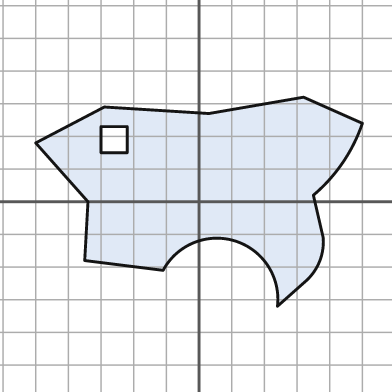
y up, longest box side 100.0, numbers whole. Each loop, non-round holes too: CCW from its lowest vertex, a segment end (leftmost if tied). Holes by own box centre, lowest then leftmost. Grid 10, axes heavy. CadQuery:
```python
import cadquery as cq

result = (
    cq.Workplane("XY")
    .moveTo(24.0, -32.0)
    .lineTo(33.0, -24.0)
    .threePointArc((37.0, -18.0), (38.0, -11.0))
    .lineTo(35.0, 2.0)
    .threePointArc((44.0, 12.0), (50.0, 24.0))
    .lineTo(32.0, 32.0)
    .lineTo(3.0, 27.0)
    .lineTo(-29.0, 29.0)
    .lineTo(-50.0, 18.0)
    .lineTo(-34.0, 0.0)
    .lineTo(-35.0, -18.0)
    .lineTo(-11.0, -21.0)
    .threePointArc((11.0, -12.0), (24.0, -32.0))
    .close()
    .moveTo(-30.0, 15.0)
    .lineTo(-22.0, 15.0)
    .lineTo(-22.0, 23.0)
    .lineTo(-30.0, 23.0)
    .close()
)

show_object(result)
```